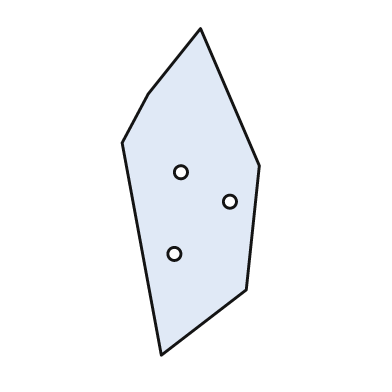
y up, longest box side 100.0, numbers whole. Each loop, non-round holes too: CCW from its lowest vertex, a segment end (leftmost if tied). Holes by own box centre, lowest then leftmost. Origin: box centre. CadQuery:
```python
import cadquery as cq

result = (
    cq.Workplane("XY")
    .moveTo(-9.0, -50.0)
    .lineTo(17.0, -30.0)
    .lineTo(21.0, 8.0)
    .lineTo(3.0, 50.0)
    .lineTo(-13.0, 30.0)
    .lineTo(-21.0, 15.0)
    .close()
    .moveTo(-5.0, -19.0)
    .circle(2.0)
    .moveTo(12.0, -3.0)
    .circle(2.0)
    .moveTo(-3.0, 6.0)
    .circle(2.0)
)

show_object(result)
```